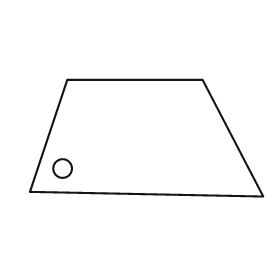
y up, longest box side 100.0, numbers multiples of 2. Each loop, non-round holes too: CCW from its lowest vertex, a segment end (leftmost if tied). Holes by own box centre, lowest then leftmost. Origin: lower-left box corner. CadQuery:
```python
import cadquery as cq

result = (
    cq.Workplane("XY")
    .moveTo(100.0, 0.0)
    .lineTo(74.0, 50.0)
    .lineTo(16.0, 50.0)
    .lineTo(0.0, 2.0)
    .close()
    .moveTo(14.0, 12.0)
    .circle(4.0)
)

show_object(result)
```